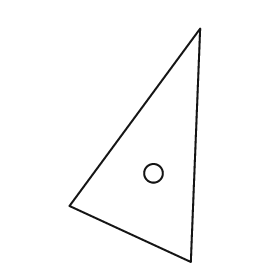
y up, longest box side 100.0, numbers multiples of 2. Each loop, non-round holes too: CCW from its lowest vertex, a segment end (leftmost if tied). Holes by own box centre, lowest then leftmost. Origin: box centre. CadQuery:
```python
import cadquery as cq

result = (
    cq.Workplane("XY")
    .moveTo(24.0, -50.0)
    .lineTo(28.0, 50.0)
    .lineTo(-28.0, -26.0)
    .close()
    .moveTo(8.0, -12.0)
    .circle(4.0)
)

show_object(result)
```